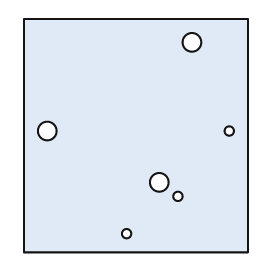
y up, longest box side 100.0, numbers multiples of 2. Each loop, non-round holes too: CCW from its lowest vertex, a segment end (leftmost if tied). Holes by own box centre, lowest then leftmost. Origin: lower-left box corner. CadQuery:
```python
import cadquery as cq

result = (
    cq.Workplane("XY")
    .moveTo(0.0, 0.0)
    .lineTo(96.0, 0.0)
    .lineTo(96.0, 100.0)
    .lineTo(0.0, 100.0)
    .close()
    .moveTo(44.0, 8.0)
    .circle(2.0)
    .moveTo(66.0, 24.0)
    .circle(2.0)
    .moveTo(58.0, 30.0)
    .circle(4.0)
    .moveTo(10.0, 52.0)
    .circle(4.0)
    .moveTo(88.0, 52.0)
    .circle(2.0)
    .moveTo(72.0, 90.0)
    .circle(4.0)
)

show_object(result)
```